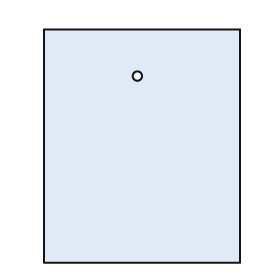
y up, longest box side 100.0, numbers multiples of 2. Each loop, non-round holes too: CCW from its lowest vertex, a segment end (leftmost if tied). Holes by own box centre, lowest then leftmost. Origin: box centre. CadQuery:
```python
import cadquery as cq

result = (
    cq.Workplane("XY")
    .moveTo(-42.0, -50.0)
    .lineTo(42.0, -50.0)
    .lineTo(42.0, 50.0)
    .lineTo(-42.0, 50.0)
    .close()
    .moveTo(-2.0, 30.0)
    .circle(2.0)
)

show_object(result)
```